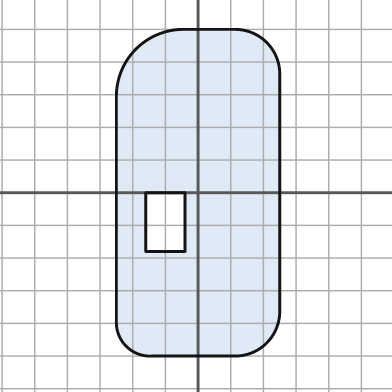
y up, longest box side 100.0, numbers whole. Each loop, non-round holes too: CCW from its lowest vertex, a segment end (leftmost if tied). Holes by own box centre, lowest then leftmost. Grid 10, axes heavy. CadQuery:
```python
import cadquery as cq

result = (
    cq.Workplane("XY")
    .moveTo(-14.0, -50.0)
    .lineTo(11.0, -50.0)
    .threePointArc((21.0, -46.0), (25.0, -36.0))
    .lineTo(25.0, 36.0)
    .threePointArc((21.0, 46.0), (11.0, 50.0))
    .lineTo(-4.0, 50.0)
    .threePointArc((-19.0, 44.0), (-25.0, 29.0))
    .lineTo(-25.0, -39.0)
    .threePointArc((-22.0, -47.0), (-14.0, -50.0))
    .close()
    .moveTo(-16.0, -18.0)
    .lineTo(-4.0, -18.0)
    .lineTo(-4.0, 0.0)
    .lineTo(-16.0, 0.0)
    .close()
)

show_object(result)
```